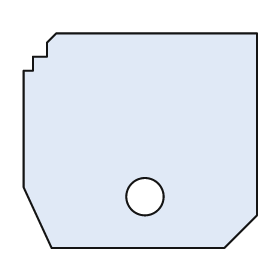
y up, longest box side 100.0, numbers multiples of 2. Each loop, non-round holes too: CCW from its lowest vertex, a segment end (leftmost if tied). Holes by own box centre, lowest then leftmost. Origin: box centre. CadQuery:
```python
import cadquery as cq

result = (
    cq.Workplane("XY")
    .moveTo(-38.0, -46.0)
    .lineTo(36.0, -46.0)
    .lineTo(50.0, -32.0)
    .lineTo(50.0, 46.0)
    .lineTo(-36.0, 46.0)
    .lineTo(-40.0, 42.0)
    .lineTo(-40.0, 36.0)
    .lineTo(-46.0, 36.0)
    .lineTo(-46.0, 30.0)
    .lineTo(-50.0, 30.0)
    .lineTo(-50.0, -20.0)
    .close()
    .moveTo(2.0, -24.0)
    .circle(8.0)
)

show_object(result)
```